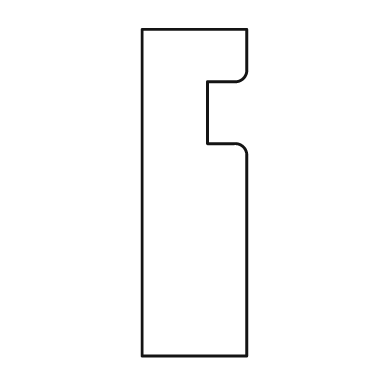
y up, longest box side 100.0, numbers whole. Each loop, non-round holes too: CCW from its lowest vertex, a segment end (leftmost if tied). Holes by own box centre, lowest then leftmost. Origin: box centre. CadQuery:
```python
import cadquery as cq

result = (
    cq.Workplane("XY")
    .moveTo(-16.0, -50.0)
    .lineTo(16.0, -50.0)
    .lineTo(16.0, 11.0)
    .threePointArc((15.0, 14.0), (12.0, 15.0))
    .lineTo(4.0, 15.0)
    .lineTo(4.0, 34.0)
    .lineTo(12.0, 34.0)
    .threePointArc((15.0, 35.0), (16.0, 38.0))
    .lineTo(16.0, 50.0)
    .lineTo(-16.0, 50.0)
    .close()
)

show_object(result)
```